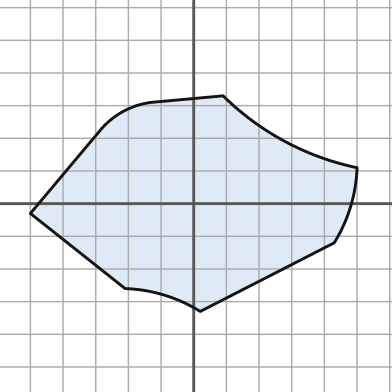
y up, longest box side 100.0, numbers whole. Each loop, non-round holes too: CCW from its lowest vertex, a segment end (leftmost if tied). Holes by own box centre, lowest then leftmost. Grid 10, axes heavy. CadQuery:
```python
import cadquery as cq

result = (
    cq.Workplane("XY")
    .moveTo(2.0, -33.0)
    .lineTo(43.0, -12.0)
    .threePointArc((48.0, -1.0), (50.0, 11.0))
    .threePointArc((28.0, 19.0), (9.0, 33.0))
    .lineTo(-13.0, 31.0)
    .threePointArc((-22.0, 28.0), (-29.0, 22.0))
    .lineTo(-50.0, -3.0)
    .lineTo(-21.0, -26.0)
    .threePointArc((-9.0, -28.0), (2.0, -33.0))
    .close()
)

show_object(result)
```